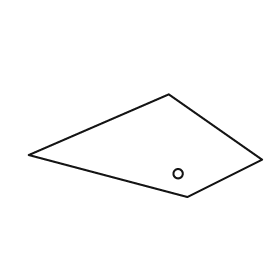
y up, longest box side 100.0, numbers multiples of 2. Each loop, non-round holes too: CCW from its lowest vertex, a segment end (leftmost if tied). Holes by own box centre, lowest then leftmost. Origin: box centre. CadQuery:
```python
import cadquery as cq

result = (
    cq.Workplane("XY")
    .moveTo(18.0, -22.0)
    .lineTo(50.0, -6.0)
    .lineTo(10.0, 22.0)
    .lineTo(-50.0, -4.0)
    .close()
    .moveTo(14.0, -12.0)
    .circle(2.0)
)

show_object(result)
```